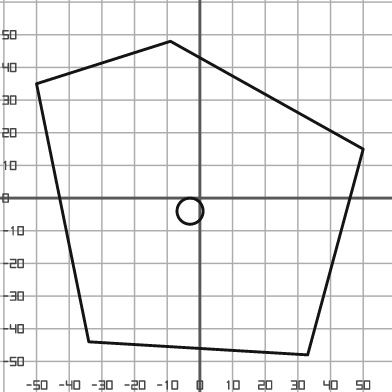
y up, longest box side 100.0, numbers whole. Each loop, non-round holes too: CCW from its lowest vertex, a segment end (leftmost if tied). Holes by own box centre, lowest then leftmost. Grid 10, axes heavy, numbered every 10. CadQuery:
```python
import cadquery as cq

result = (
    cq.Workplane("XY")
    .moveTo(33.0, -48.0)
    .lineTo(50.0, 15.0)
    .lineTo(-9.0, 48.0)
    .lineTo(-50.0, 35.0)
    .lineTo(-34.0, -44.0)
    .close()
    .moveTo(-3.0, -4.0)
    .circle(4.0)
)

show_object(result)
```